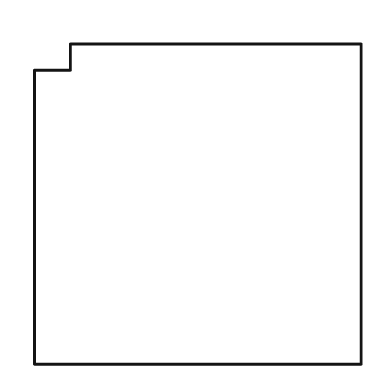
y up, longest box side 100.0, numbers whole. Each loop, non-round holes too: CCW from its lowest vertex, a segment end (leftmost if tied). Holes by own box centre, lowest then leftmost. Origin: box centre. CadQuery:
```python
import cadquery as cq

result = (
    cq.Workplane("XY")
    .moveTo(-50.0, -49.0)
    .lineTo(50.0, -49.0)
    .lineTo(50.0, 49.0)
    .lineTo(-39.0, 49.0)
    .lineTo(-39.0, 41.0)
    .lineTo(-50.0, 41.0)
    .close()
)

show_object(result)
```